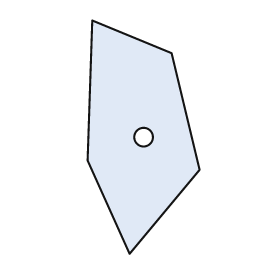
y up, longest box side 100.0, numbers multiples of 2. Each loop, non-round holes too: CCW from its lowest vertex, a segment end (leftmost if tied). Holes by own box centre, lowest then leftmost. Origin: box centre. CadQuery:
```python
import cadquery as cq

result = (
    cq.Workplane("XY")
    .moveTo(-6.0, -50.0)
    .lineTo(24.0, -14.0)
    .lineTo(12.0, 36.0)
    .lineTo(-22.0, 50.0)
    .lineTo(-24.0, -10.0)
    .close()
    .moveTo(0.0, 0.0)
    .circle(4.0)
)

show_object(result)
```